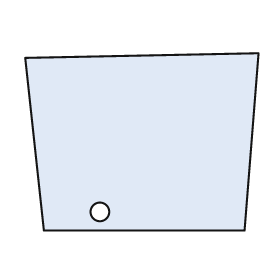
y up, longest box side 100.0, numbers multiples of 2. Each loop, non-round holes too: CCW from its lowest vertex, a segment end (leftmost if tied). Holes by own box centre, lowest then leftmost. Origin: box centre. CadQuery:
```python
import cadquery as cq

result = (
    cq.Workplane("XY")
    .moveTo(-42.0, -38.0)
    .lineTo(44.0, -38.0)
    .lineTo(50.0, 38.0)
    .lineTo(-50.0, 36.0)
    .close()
    .moveTo(-18.0, -30.0)
    .circle(4.0)
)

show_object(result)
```